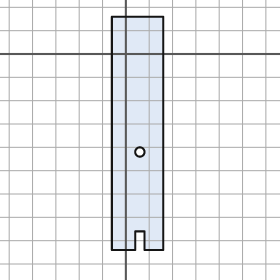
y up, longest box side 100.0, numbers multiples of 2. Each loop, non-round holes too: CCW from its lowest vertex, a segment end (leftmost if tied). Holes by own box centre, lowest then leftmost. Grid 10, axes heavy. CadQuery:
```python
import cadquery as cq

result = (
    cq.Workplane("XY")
    .moveTo(-6.0, -84.0)
    .lineTo(4.0, -84.0)
    .lineTo(4.0, -76.0)
    .lineTo(8.0, -76.0)
    .lineTo(8.0, -84.0)
    .lineTo(16.0, -84.0)
    .lineTo(16.0, 16.0)
    .lineTo(-6.0, 16.0)
    .close()
    .moveTo(6.0, -42.0)
    .circle(2.0)
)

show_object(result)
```